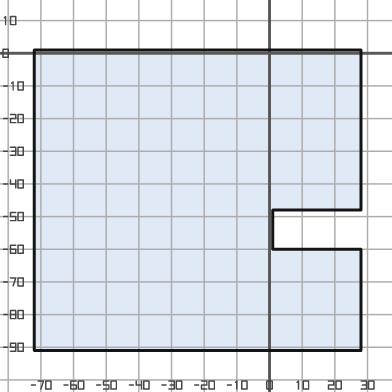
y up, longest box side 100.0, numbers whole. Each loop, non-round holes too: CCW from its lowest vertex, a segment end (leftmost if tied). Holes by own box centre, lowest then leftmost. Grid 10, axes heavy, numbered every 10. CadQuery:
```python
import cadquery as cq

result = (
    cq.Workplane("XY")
    .moveTo(-72.0, -91.0)
    .lineTo(28.0, -91.0)
    .lineTo(28.0, -60.0)
    .lineTo(1.0, -60.0)
    .lineTo(1.0, -48.0)
    .lineTo(28.0, -48.0)
    .lineTo(28.0, 1.0)
    .lineTo(-72.0, 1.0)
    .close()
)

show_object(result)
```